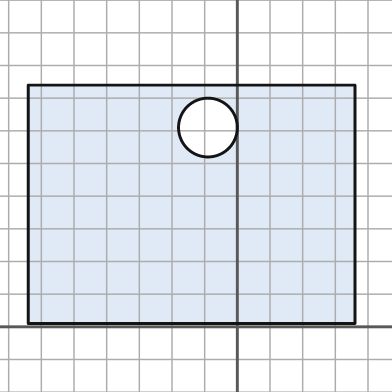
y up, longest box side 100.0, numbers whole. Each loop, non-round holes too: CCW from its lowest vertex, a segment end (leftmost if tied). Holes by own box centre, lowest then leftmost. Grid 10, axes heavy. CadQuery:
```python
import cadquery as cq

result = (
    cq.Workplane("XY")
    .moveTo(-64.0, 1.0)
    .lineTo(36.0, 1.0)
    .lineTo(36.0, 74.0)
    .lineTo(-64.0, 74.0)
    .close()
    .moveTo(-9.0, 61.0)
    .circle(9.0)
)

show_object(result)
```